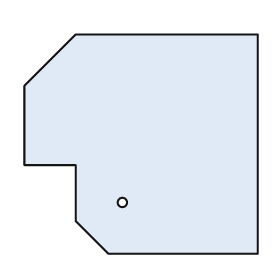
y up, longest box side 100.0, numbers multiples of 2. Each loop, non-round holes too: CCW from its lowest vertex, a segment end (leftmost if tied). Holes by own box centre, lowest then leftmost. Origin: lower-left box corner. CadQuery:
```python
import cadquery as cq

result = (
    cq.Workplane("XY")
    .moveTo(36.0, 0.0)
    .lineTo(100.0, 0.0)
    .lineTo(100.0, 94.0)
    .lineTo(22.0, 94.0)
    .lineTo(0.0, 72.0)
    .lineTo(0.0, 38.0)
    .lineTo(22.0, 38.0)
    .lineTo(22.0, 14.0)
    .close()
    .moveTo(42.0, 22.0)
    .circle(2.0)
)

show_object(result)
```